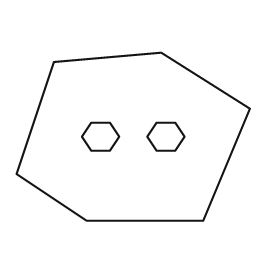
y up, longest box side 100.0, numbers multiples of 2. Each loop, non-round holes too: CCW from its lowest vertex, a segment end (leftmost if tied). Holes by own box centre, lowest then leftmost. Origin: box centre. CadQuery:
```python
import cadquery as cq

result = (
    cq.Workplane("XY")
    .moveTo(-20.0, -36.0)
    .lineTo(30.0, -36.0)
    .lineTo(50.0, 12.0)
    .lineTo(12.0, 36.0)
    .lineTo(-34.0, 32.0)
    .lineTo(-50.0, -16.0)
    .close()
    .moveTo(-18.0, -6.0)
    .lineTo(-10.0, -6.0)
    .lineTo(-6.0, 0.0)
    .lineTo(-10.0, 6.0)
    .lineTo(-18.0, 6.0)
    .lineTo(-22.0, 0.0)
    .close()
    .moveTo(10.0, -6.0)
    .lineTo(18.0, -6.0)
    .lineTo(22.0, 0.0)
    .lineTo(18.0, 6.0)
    .lineTo(10.0, 6.0)
    .lineTo(6.0, 0.0)
    .close()
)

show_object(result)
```